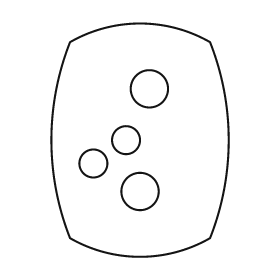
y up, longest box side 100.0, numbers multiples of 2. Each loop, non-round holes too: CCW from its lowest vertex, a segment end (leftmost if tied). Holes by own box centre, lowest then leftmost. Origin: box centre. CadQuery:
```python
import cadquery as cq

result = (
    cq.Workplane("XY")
    .moveTo(-30.0, -42.0)
    .threePointArc((0.0, -50.0), (30.0, -42.0))
    .threePointArc((38.0, 0.0), (30.0, 42.0))
    .threePointArc((0.0, 50.0), (-30.0, 42.0))
    .threePointArc((-38.0, 0.0), (-30.0, -42.0))
    .close()
    .moveTo(0.0, -22.0)
    .circle(8.0)
    .moveTo(-20.0, -10.0)
    .circle(6.0)
    .moveTo(-6.0, 0.0)
    .circle(6.0)
    .moveTo(4.0, 22.0)
    .circle(8.0)
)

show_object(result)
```